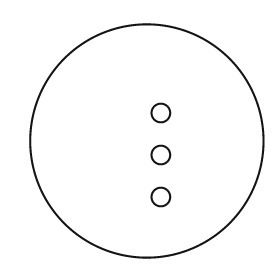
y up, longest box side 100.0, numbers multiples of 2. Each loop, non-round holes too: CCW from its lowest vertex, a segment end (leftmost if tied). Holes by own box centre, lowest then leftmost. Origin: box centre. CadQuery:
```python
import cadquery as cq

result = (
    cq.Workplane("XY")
    .moveTo(0.0, 0.0)
    .circle(50.0)
    .moveTo(6.0, -24.0)
    .circle(4.0)
    .moveTo(6.0, -6.0)
    .circle(4.0)
    .moveTo(6.0, 12.0)
    .circle(4.0)
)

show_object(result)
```